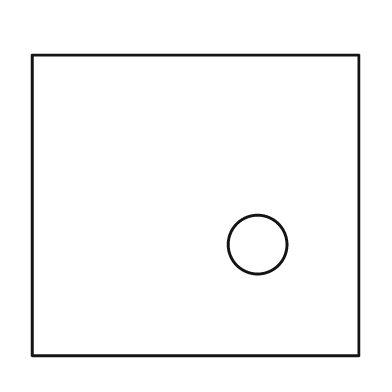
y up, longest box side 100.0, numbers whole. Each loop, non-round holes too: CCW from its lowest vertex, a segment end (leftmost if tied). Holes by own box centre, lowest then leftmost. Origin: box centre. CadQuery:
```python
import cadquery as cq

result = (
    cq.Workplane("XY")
    .moveTo(-50.0, -46.0)
    .lineTo(50.0, -46.0)
    .lineTo(50.0, 46.0)
    .lineTo(-50.0, 46.0)
    .close()
    .moveTo(19.0, -12.0)
    .circle(9.0)
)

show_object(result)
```